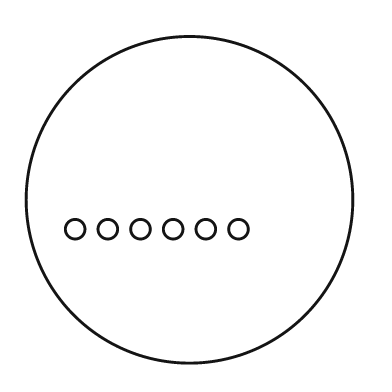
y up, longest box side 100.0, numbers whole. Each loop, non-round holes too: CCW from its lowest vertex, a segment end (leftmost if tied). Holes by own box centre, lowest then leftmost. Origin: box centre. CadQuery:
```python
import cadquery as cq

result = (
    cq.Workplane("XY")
    .moveTo(0.0, 0.0)
    .circle(50.0)
    .moveTo(-35.0, -9.0)
    .circle(3.0)
    .moveTo(-25.0, -9.0)
    .circle(3.0)
    .moveTo(-15.0, -9.0)
    .circle(3.0)
    .moveTo(-5.0, -9.0)
    .circle(3.0)
    .moveTo(5.0, -9.0)
    .circle(3.0)
    .moveTo(15.0, -9.0)
    .circle(3.0)
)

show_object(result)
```